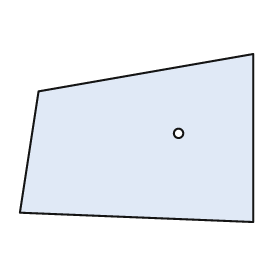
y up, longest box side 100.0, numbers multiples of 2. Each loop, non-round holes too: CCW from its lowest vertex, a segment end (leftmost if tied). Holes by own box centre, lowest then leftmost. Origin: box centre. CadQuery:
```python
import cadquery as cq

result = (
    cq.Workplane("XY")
    .moveTo(50.0, -36.0)
    .lineTo(50.0, 36.0)
    .lineTo(-42.0, 20.0)
    .lineTo(-50.0, -32.0)
    .close()
    .moveTo(18.0, 2.0)
    .circle(2.0)
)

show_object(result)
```